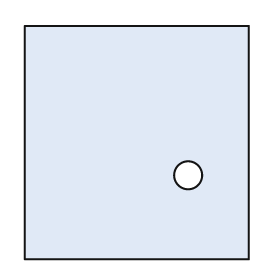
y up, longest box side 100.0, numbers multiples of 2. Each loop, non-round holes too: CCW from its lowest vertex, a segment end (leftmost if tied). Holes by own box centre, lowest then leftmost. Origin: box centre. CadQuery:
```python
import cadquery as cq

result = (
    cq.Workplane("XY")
    .moveTo(-48.0, -50.0)
    .lineTo(48.0, -50.0)
    .lineTo(48.0, 50.0)
    .lineTo(-48.0, 50.0)
    .close()
    .moveTo(22.0, -14.0)
    .circle(6.0)
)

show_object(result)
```